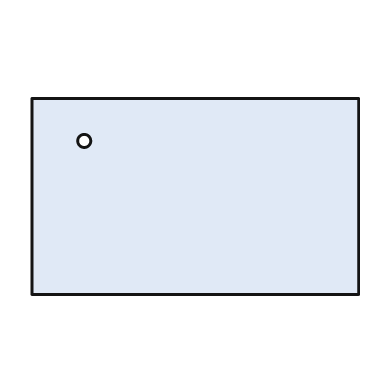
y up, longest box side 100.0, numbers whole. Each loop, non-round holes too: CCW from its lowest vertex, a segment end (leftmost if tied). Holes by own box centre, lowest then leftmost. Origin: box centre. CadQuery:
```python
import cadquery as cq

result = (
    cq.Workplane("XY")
    .moveTo(-50.0, -30.0)
    .lineTo(50.0, -30.0)
    .lineTo(50.0, 30.0)
    .lineTo(-50.0, 30.0)
    .close()
    .moveTo(-34.0, 17.0)
    .circle(2.0)
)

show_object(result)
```